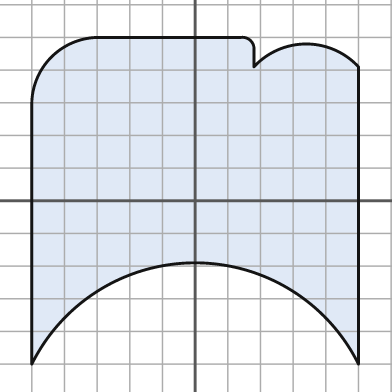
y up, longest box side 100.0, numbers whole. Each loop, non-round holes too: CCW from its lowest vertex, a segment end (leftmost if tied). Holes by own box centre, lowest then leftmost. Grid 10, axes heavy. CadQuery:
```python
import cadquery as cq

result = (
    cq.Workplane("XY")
    .moveTo(-50.0, -50.0)
    .threePointArc((0.0, -19.0), (50.0, -50.0))
    .lineTo(50.0, 41.0)
    .threePointArc((34.0, 48.0), (18.0, 41.0))
    .lineTo(18.0, 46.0)
    .threePointArc((17.0, 49.0), (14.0, 50.0))
    .lineTo(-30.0, 50.0)
    .threePointArc((-44.0, 44.0), (-50.0, 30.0))
    .close()
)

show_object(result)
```